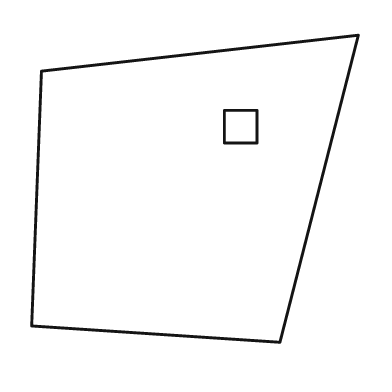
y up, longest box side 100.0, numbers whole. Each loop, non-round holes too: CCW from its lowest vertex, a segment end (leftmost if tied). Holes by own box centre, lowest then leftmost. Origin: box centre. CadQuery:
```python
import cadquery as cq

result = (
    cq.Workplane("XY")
    .moveTo(26.0, -47.0)
    .lineTo(50.0, 47.0)
    .lineTo(-47.0, 36.0)
    .lineTo(-50.0, -42.0)
    .close()
    .moveTo(9.0, 14.0)
    .lineTo(19.0, 14.0)
    .lineTo(19.0, 24.0)
    .lineTo(9.0, 24.0)
    .close()
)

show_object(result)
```